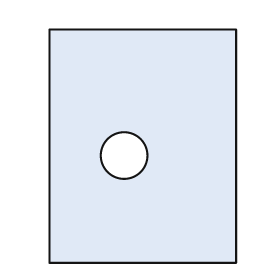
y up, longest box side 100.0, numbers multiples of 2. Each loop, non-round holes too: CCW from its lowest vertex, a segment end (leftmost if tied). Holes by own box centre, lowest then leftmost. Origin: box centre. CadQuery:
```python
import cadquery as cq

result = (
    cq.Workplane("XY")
    .moveTo(-40.0, -50.0)
    .lineTo(40.0, -50.0)
    .lineTo(40.0, 50.0)
    .lineTo(-40.0, 50.0)
    .close()
    .moveTo(-8.0, -4.0)
    .circle(10.0)
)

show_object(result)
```